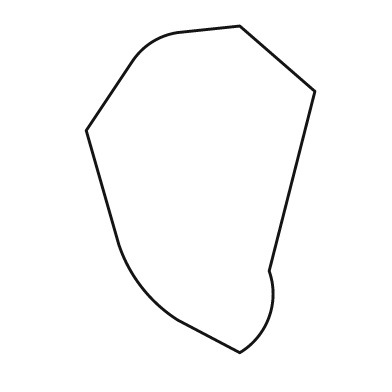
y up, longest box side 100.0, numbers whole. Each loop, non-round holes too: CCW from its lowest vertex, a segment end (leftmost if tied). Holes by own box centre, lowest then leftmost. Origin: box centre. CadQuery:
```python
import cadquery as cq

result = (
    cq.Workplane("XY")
    .moveTo(12.0, -50.0)
    .threePointArc((21.0, -39.0), (21.0, -25.0))
    .lineTo(35.0, 30.0)
    .lineTo(12.0, 50.0)
    .lineTo(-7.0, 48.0)
    .threePointArc((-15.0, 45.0), (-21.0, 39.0))
    .lineTo(-35.0, 18.0)
    .lineTo(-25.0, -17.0)
    .threePointArc((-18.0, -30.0), (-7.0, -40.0))
    .close()
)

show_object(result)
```